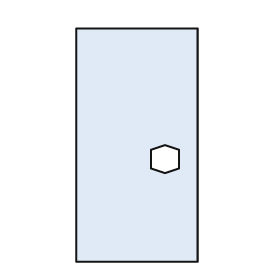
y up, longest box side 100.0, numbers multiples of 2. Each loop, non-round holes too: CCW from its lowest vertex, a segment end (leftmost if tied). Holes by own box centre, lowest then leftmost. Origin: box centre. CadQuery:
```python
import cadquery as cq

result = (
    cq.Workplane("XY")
    .moveTo(-26.0, -50.0)
    .lineTo(26.0, -50.0)
    .lineTo(26.0, 50.0)
    .lineTo(-26.0, 50.0)
    .close()
    .moveTo(12.0, -12.0)
    .lineTo(18.0, -10.0)
    .lineTo(18.0, -2.0)
    .lineTo(12.0, 0.0)
    .lineTo(6.0, -2.0)
    .lineTo(6.0, -10.0)
    .close()
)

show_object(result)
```